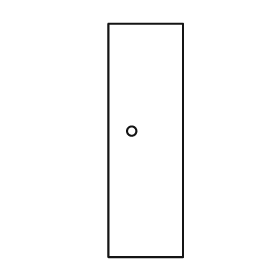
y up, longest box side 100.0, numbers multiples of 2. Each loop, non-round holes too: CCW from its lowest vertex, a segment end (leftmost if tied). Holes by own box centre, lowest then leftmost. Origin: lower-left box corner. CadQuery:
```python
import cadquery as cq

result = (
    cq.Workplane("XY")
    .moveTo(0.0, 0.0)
    .lineTo(32.0, 0.0)
    .lineTo(32.0, 100.0)
    .lineTo(0.0, 100.0)
    .close()
    .moveTo(10.0, 54.0)
    .circle(2.0)
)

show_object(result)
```